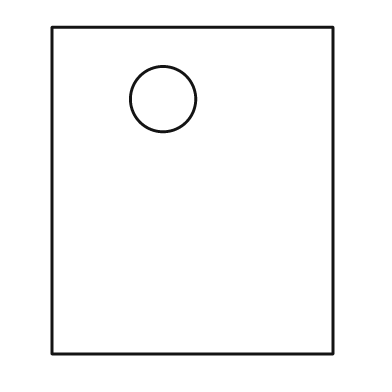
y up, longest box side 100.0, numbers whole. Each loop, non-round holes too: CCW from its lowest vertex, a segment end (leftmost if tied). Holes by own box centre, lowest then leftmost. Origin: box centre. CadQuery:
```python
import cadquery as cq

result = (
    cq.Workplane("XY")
    .moveTo(-43.0, -50.0)
    .lineTo(43.0, -50.0)
    .lineTo(43.0, 50.0)
    .lineTo(-43.0, 50.0)
    .close()
    .moveTo(-9.0, 28.0)
    .circle(10.0)
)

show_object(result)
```